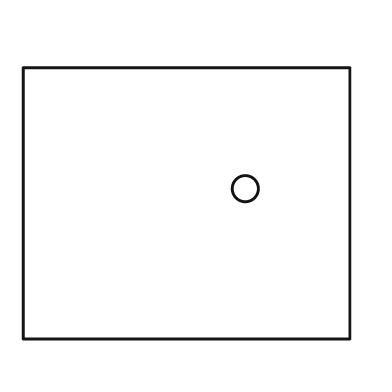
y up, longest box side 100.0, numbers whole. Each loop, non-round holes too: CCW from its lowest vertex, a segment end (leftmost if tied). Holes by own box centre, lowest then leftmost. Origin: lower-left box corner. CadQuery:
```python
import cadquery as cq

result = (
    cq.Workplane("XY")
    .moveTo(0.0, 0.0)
    .lineTo(100.0, 0.0)
    .lineTo(100.0, 83.0)
    .lineTo(0.0, 83.0)
    .close()
    .moveTo(68.0, 46.0)
    .circle(4.0)
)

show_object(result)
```